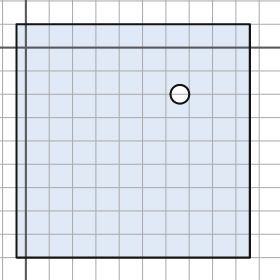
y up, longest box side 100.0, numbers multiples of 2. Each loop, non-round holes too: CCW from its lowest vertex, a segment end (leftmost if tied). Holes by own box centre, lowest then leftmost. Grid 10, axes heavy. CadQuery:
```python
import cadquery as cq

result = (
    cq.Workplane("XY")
    .moveTo(-4.0, -90.0)
    .lineTo(96.0, -90.0)
    .lineTo(96.0, 10.0)
    .lineTo(-4.0, 10.0)
    .close()
    .moveTo(66.0, -20.0)
    .circle(4.0)
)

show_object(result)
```